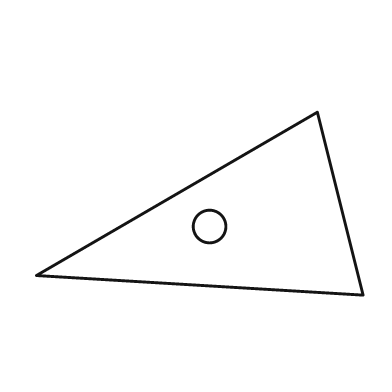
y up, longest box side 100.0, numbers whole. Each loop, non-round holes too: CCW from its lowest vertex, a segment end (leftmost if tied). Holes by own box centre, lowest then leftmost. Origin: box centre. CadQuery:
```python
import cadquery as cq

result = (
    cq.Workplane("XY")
    .moveTo(50.0, -28.0)
    .lineTo(36.0, 28.0)
    .lineTo(-50.0, -22.0)
    .close()
    .moveTo(3.0, -7.0)
    .circle(5.0)
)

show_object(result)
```